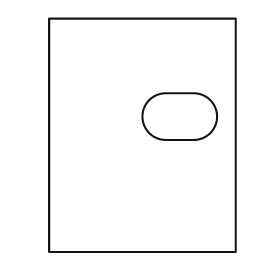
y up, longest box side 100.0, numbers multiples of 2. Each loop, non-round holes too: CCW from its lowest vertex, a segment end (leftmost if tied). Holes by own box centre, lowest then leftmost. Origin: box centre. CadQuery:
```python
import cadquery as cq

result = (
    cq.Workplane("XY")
    .moveTo(-40.0, -50.0)
    .lineTo(40.0, -50.0)
    .lineTo(40.0, 50.0)
    .lineTo(-40.0, 50.0)
    .close()
    .moveTo(10.0, -2.0)
    .lineTo(22.0, -2.0)
    .threePointArc((32.0, 8.0), (22.0, 18.0))
    .lineTo(10.0, 18.0)
    .threePointArc((0.0, 8.0), (10.0, -2.0))
    .close()
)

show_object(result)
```